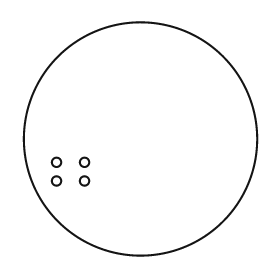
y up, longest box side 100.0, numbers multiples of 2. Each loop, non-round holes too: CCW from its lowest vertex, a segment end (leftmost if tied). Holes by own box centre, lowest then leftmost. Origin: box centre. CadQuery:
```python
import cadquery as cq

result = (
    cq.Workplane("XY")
    .moveTo(0.0, 0.0)
    .circle(50.0)
    .moveTo(-36.0, -18.0)
    .circle(2.0)
    .moveTo(-24.0, -18.0)
    .circle(2.0)
    .moveTo(-36.0, -10.0)
    .circle(2.0)
    .moveTo(-24.0, -10.0)
    .circle(2.0)
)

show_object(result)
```